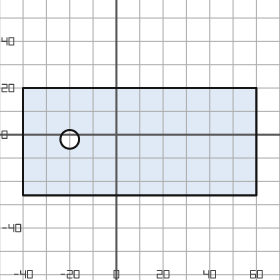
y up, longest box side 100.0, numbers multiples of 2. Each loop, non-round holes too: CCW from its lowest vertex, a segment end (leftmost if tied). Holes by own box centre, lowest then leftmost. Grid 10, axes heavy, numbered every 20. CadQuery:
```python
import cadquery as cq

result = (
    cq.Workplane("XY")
    .moveTo(-40.0, -26.0)
    .lineTo(60.0, -26.0)
    .lineTo(60.0, 20.0)
    .lineTo(-40.0, 20.0)
    .close()
    .moveTo(-20.0, -2.0)
    .circle(4.0)
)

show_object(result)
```